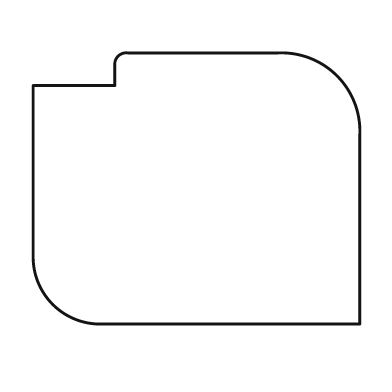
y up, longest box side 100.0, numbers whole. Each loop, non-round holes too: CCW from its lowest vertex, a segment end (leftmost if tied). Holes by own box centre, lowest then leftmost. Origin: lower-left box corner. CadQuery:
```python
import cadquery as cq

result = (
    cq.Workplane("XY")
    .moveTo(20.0, 0.0)
    .lineTo(100.0, 0.0)
    .lineTo(100.0, 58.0)
    .threePointArc((93.0, 76.0), (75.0, 83.0))
    .lineTo(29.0, 83.0)
    .threePointArc((26.0, 82.0), (25.0, 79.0))
    .lineTo(25.0, 73.0)
    .lineTo(0.0, 73.0)
    .lineTo(0.0, 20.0)
    .threePointArc((6.0, 6.0), (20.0, 0.0))
    .close()
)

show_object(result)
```